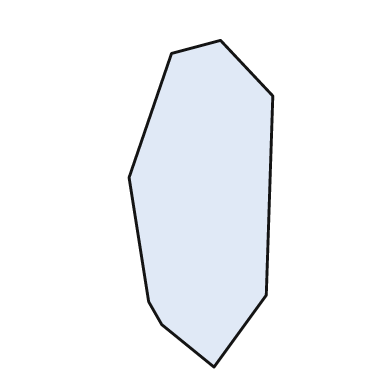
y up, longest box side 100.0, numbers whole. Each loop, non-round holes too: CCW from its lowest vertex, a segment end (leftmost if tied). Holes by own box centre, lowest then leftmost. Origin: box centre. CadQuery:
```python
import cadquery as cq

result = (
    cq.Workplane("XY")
    .moveTo(4.0, -50.0)
    .lineTo(20.0, -28.0)
    .lineTo(22.0, 33.0)
    .lineTo(6.0, 50.0)
    .lineTo(-9.0, 46.0)
    .lineTo(-22.0, 8.0)
    .lineTo(-16.0, -30.0)
    .lineTo(-12.0, -37.0)
    .close()
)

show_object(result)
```